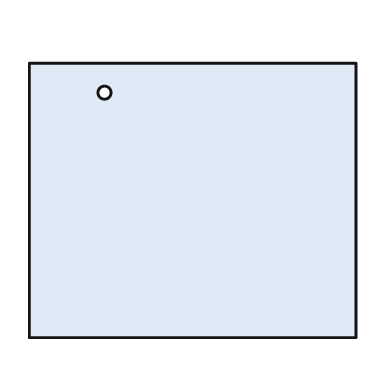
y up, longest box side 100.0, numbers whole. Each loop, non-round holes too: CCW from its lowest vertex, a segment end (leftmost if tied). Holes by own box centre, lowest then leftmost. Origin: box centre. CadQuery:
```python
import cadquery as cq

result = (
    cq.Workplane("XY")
    .moveTo(-50.0, -42.0)
    .lineTo(50.0, -42.0)
    .lineTo(50.0, 42.0)
    .lineTo(-50.0, 42.0)
    .close()
    .moveTo(-27.0, 33.0)
    .circle(2.0)
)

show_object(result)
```